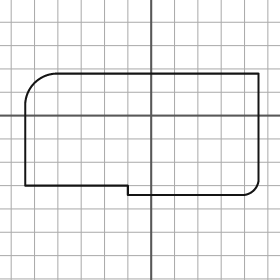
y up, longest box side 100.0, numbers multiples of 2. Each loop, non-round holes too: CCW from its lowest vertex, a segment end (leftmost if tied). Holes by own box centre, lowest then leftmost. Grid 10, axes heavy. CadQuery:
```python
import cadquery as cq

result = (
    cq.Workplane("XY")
    .moveTo(-10.0, -34.0)
    .lineTo(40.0, -34.0)
    .threePointArc((44.0, -32.0), (46.0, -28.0))
    .lineTo(46.0, 18.0)
    .lineTo(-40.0, 18.0)
    .threePointArc((-50.0, 14.0), (-54.0, 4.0))
    .lineTo(-54.0, -30.0)
    .lineTo(-10.0, -30.0)
    .close()
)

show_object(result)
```